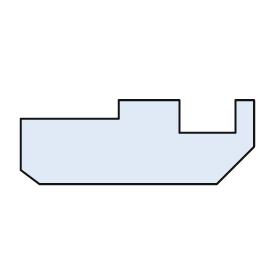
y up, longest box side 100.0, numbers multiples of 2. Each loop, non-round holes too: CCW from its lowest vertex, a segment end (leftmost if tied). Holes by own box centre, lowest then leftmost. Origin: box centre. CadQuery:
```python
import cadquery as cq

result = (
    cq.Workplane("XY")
    .moveTo(-42.0, -18.0)
    .lineTo(34.0, -18.0)
    .lineTo(50.0, -2.0)
    .lineTo(50.0, 18.0)
    .lineTo(42.0, 18.0)
    .lineTo(42.0, 4.0)
    .lineTo(18.0, 4.0)
    .lineTo(18.0, 18.0)
    .lineTo(-8.0, 18.0)
    .lineTo(-8.0, 10.0)
    .lineTo(-50.0, 10.0)
    .lineTo(-50.0, -12.0)
    .close()
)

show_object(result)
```